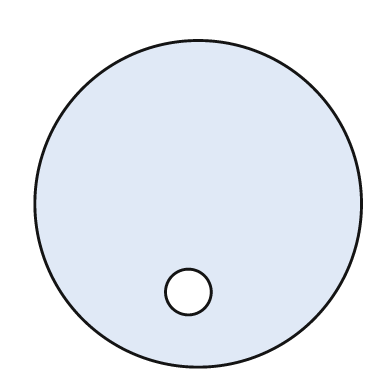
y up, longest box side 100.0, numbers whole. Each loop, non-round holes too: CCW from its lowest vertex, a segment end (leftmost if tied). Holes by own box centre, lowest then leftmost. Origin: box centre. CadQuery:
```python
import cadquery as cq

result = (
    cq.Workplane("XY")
    .moveTo(0.0, 0.0)
    .circle(50.0)
    .moveTo(-3.0, -27.0)
    .circle(7.0)
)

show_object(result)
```